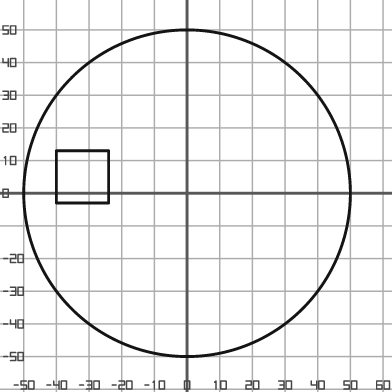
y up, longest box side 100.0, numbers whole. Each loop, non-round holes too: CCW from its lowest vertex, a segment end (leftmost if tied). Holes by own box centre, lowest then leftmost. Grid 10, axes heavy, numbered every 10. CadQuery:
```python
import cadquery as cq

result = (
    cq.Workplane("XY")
    .moveTo(0.0, 0.0)
    .circle(50.0)
    .moveTo(-40.0, -3.0)
    .lineTo(-24.0, -3.0)
    .lineTo(-24.0, 13.0)
    .lineTo(-40.0, 13.0)
    .close()
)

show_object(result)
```